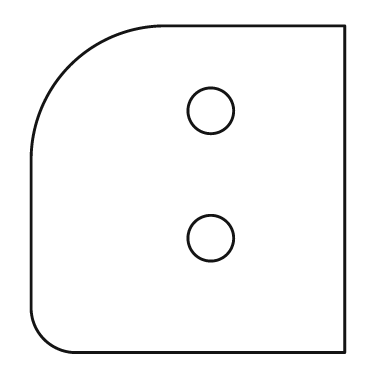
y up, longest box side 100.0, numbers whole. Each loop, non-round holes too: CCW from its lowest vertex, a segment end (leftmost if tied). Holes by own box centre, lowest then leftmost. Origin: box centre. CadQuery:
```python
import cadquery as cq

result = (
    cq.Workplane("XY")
    .moveTo(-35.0, -50.0)
    .lineTo(48.0, -50.0)
    .lineTo(48.0, 50.0)
    .lineTo(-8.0, 50.0)
    .threePointArc((-36.0, 38.0), (-48.0, 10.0))
    .lineTo(-48.0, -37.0)
    .threePointArc((-44.0, -46.0), (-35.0, -50.0))
    .close()
    .moveTo(7.0, -15.0)
    .circle(7.0)
    .moveTo(7.0, 24.0)
    .circle(7.0)
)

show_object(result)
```